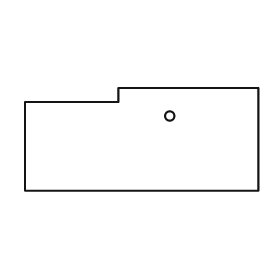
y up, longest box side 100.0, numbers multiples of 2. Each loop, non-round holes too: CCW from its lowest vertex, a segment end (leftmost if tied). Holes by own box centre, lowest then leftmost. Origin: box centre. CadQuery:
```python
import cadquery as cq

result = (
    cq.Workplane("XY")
    .moveTo(-50.0, -22.0)
    .lineTo(50.0, -22.0)
    .lineTo(50.0, 22.0)
    .lineTo(-10.0, 22.0)
    .lineTo(-10.0, 16.0)
    .lineTo(-50.0, 16.0)
    .close()
    .moveTo(12.0, 10.0)
    .circle(2.0)
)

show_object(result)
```